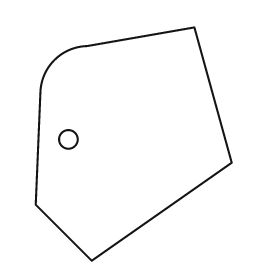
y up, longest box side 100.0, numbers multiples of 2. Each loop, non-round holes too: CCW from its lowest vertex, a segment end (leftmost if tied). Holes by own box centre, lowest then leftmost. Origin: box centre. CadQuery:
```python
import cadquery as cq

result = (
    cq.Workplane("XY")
    .moveTo(-18.0, -50.0)
    .lineTo(42.0, -8.0)
    .lineTo(26.0, 50.0)
    .lineTo(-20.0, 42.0)
    .threePointArc((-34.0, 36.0), (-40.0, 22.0))
    .lineTo(-42.0, -26.0)
    .close()
    .moveTo(-28.0, 2.0)
    .circle(4.0)
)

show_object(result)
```